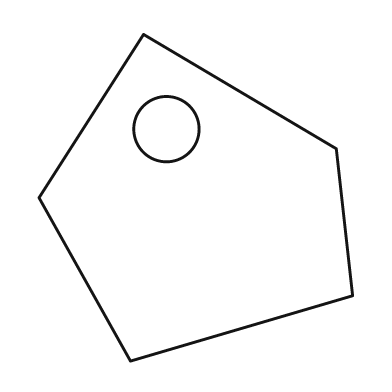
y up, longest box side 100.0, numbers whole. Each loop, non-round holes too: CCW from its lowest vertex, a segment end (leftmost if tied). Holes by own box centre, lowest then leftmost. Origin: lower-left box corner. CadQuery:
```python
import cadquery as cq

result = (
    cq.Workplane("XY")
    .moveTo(28.0, 0.0)
    .lineTo(96.0, 20.0)
    .lineTo(91.0, 65.0)
    .lineTo(32.0, 100.0)
    .lineTo(0.0, 50.0)
    .close()
    .moveTo(39.0, 71.0)
    .circle(10.0)
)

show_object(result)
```